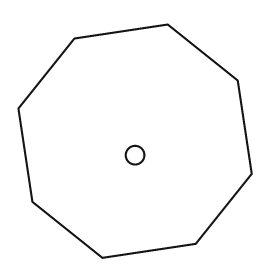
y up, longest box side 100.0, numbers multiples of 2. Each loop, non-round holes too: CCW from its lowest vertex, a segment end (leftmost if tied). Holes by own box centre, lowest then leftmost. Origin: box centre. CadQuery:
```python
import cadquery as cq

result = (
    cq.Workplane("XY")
    .moveTo(-14.0, -50.0)
    .lineTo(26.0, -44.0)
    .lineTo(50.0, -14.0)
    .lineTo(44.0, 26.0)
    .lineTo(14.0, 50.0)
    .lineTo(-26.0, 44.0)
    .lineTo(-50.0, 14.0)
    .lineTo(-44.0, -26.0)
    .close()
    .moveTo(0.0, -6.0)
    .circle(4.0)
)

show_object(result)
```